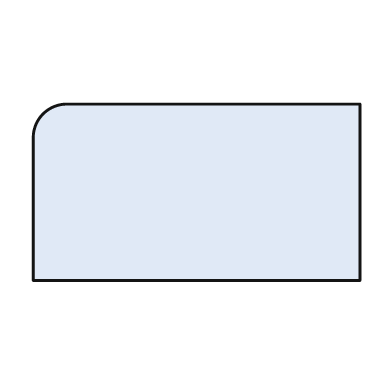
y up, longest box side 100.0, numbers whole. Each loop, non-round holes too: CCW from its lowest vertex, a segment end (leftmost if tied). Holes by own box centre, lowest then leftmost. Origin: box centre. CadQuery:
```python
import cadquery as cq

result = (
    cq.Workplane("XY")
    .moveTo(-50.0, -27.0)
    .lineTo(50.0, -27.0)
    .lineTo(50.0, 27.0)
    .lineTo(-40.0, 27.0)
    .threePointArc((-47.0, 24.0), (-50.0, 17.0))
    .close()
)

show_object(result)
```